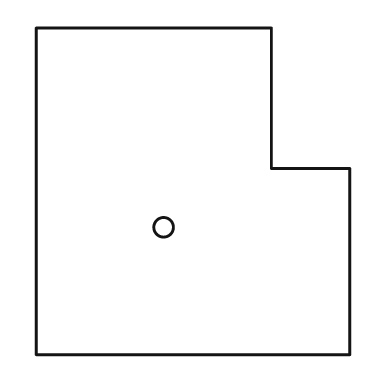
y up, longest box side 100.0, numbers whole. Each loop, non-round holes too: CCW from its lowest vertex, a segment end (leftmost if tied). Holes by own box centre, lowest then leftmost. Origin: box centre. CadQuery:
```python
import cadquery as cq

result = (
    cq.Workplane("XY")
    .moveTo(-48.0, -50.0)
    .lineTo(48.0, -50.0)
    .lineTo(48.0, 7.0)
    .lineTo(24.0, 7.0)
    .lineTo(24.0, 50.0)
    .lineTo(-48.0, 50.0)
    .close()
    .moveTo(-9.0, -11.0)
    .circle(3.0)
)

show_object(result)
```